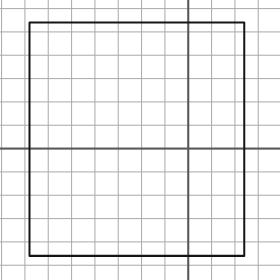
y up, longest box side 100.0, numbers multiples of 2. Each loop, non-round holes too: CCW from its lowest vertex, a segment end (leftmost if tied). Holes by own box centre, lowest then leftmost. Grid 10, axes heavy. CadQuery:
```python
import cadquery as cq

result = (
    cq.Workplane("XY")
    .moveTo(-68.0, -46.0)
    .lineTo(24.0, -46.0)
    .lineTo(24.0, 54.0)
    .lineTo(-68.0, 54.0)
    .close()
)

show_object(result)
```